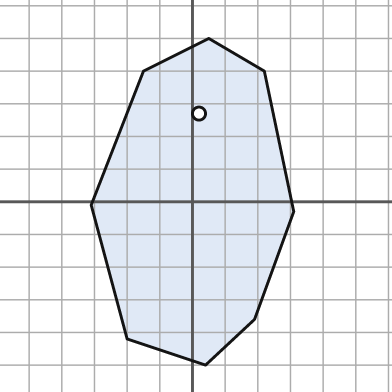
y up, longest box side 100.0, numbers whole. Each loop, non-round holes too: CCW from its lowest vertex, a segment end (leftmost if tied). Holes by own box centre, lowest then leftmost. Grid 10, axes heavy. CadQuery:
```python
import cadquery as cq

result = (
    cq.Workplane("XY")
    .moveTo(4.0, -50.0)
    .lineTo(19.0, -36.0)
    .lineTo(31.0, -3.0)
    .lineTo(22.0, 40.0)
    .lineTo(5.0, 50.0)
    .lineTo(-15.0, 40.0)
    .lineTo(-31.0, -1.0)
    .lineTo(-20.0, -42.0)
    .close()
    .moveTo(2.0, 27.0)
    .circle(2.0)
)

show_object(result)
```